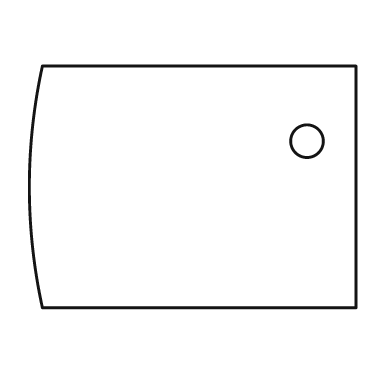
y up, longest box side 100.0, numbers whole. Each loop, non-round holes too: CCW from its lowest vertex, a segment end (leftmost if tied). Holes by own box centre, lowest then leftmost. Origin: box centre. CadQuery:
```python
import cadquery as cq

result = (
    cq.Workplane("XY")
    .moveTo(-46.0, -37.0)
    .lineTo(50.0, -37.0)
    .lineTo(50.0, 37.0)
    .lineTo(-46.0, 37.0)
    .threePointArc((-50.0, 0.0), (-46.0, -37.0))
    .close()
    .moveTo(35.0, 14.0)
    .circle(5.0)
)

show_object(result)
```